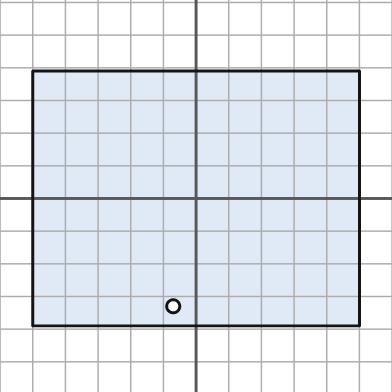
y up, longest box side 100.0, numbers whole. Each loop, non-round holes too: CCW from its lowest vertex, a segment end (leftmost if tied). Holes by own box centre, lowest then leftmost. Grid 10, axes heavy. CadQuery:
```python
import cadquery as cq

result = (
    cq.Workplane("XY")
    .moveTo(-50.0, -39.0)
    .lineTo(50.0, -39.0)
    .lineTo(50.0, 39.0)
    .lineTo(-50.0, 39.0)
    .close()
    .moveTo(-7.0, -33.0)
    .circle(2.0)
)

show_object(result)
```